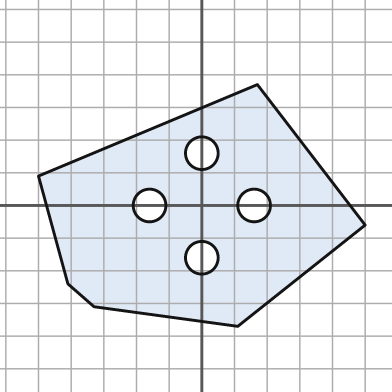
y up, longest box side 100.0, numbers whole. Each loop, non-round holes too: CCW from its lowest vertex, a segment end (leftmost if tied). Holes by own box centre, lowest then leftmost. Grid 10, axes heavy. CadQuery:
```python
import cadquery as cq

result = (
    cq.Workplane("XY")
    .moveTo(11.0, -37.0)
    .lineTo(50.0, -6.0)
    .lineTo(17.0, 37.0)
    .lineTo(-50.0, 9.0)
    .lineTo(-41.0, -24.0)
    .lineTo(-33.0, -31.0)
    .close()
    .moveTo(0.0, -16.0)
    .circle(5.0)
    .moveTo(-16.0, 0.0)
    .circle(5.0)
    .moveTo(16.0, 0.0)
    .circle(5.0)
    .moveTo(0.0, 16.0)
    .circle(5.0)
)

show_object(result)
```